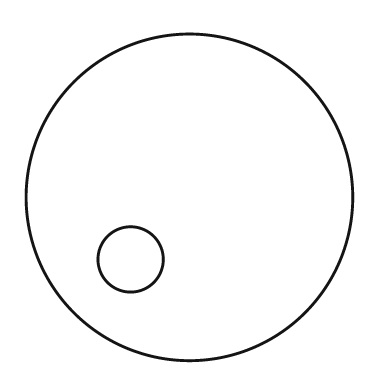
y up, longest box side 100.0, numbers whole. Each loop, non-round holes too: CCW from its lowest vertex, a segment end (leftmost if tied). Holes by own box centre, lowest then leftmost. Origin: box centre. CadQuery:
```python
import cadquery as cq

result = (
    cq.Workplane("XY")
    .moveTo(0.0, 0.0)
    .circle(50.0)
    .moveTo(-18.0, -19.0)
    .circle(10.0)
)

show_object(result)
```